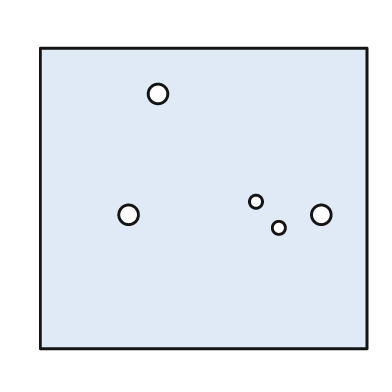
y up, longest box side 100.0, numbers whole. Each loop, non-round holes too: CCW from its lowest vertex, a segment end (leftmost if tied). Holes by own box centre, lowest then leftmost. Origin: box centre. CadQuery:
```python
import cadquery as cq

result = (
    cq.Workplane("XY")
    .moveTo(-50.0, -46.0)
    .lineTo(50.0, -46.0)
    .lineTo(50.0, 46.0)
    .lineTo(-50.0, 46.0)
    .close()
    .moveTo(23.0, -9.0)
    .circle(2.0)
    .moveTo(-23.0, -5.0)
    .circle(3.0)
    .moveTo(36.0, -5.0)
    .circle(3.0)
    .moveTo(16.0, -1.0)
    .circle(2.0)
    .moveTo(-14.0, 32.0)
    .circle(3.0)
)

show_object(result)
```